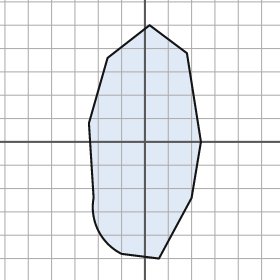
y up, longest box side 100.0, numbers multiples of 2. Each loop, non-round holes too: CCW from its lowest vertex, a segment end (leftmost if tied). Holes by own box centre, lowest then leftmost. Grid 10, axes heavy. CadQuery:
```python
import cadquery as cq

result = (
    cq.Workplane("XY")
    .moveTo(6.0, -50.0)
    .lineTo(20.0, -24.0)
    .lineTo(24.0, 0.0)
    .lineTo(18.0, 38.0)
    .lineTo(2.0, 50.0)
    .lineTo(-16.0, 36.0)
    .lineTo(-24.0, 8.0)
    .lineTo(-22.0, -24.0)
    .threePointArc((-20.0, -38.0), (-10.0, -48.0))
    .close()
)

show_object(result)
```